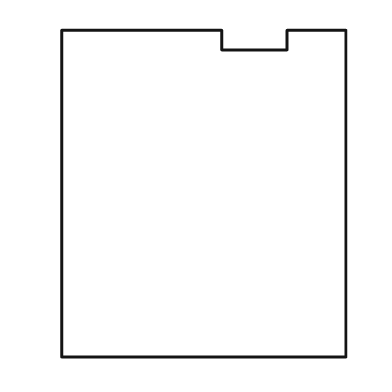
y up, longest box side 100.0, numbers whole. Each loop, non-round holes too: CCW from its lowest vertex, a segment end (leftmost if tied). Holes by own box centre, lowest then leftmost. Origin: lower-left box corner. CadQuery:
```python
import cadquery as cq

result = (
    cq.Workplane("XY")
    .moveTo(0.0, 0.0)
    .lineTo(87.0, 0.0)
    .lineTo(87.0, 100.0)
    .lineTo(69.0, 100.0)
    .lineTo(69.0, 94.0)
    .lineTo(49.0, 94.0)
    .lineTo(49.0, 100.0)
    .lineTo(0.0, 100.0)
    .close()
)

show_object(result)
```